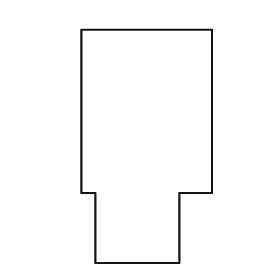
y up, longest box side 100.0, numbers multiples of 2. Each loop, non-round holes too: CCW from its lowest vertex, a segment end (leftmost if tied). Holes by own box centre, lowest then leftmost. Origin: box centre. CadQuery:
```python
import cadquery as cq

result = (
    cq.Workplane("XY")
    .moveTo(-22.0, -50.0)
    .lineTo(14.0, -50.0)
    .lineTo(14.0, -20.0)
    .lineTo(28.0, -20.0)
    .lineTo(28.0, 50.0)
    .lineTo(-28.0, 50.0)
    .lineTo(-28.0, -20.0)
    .lineTo(-22.0, -20.0)
    .close()
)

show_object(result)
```